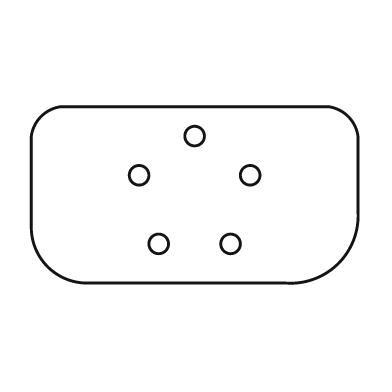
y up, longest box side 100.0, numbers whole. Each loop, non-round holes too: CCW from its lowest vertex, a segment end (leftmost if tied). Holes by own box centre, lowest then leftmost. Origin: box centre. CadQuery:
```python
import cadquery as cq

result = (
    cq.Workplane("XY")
    .moveTo(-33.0, -27.0)
    .lineTo(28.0, -27.0)
    .threePointArc((44.0, -21.0), (50.0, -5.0))
    .lineTo(50.0, 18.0)
    .threePointArc((47.0, 24.0), (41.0, 27.0))
    .lineTo(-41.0, 27.0)
    .threePointArc((-47.0, 24.0), (-50.0, 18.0))
    .lineTo(-50.0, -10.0)
    .threePointArc((-45.0, -22.0), (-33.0, -27.0))
    .close()
    .moveTo(-11.0, -15.0)
    .circle(3.0)
    .moveTo(11.0, -15.0)
    .circle(3.0)
    .moveTo(-17.0, 6.0)
    .circle(3.0)
    .moveTo(17.0, 6.0)
    .circle(3.0)
    .moveTo(0.0, 18.0)
    .circle(3.0)
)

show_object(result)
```